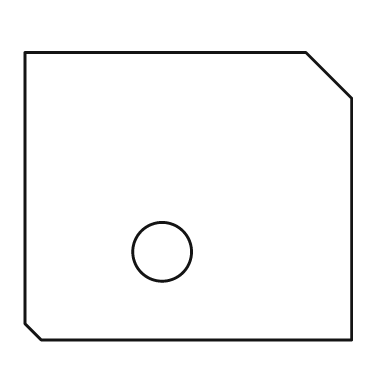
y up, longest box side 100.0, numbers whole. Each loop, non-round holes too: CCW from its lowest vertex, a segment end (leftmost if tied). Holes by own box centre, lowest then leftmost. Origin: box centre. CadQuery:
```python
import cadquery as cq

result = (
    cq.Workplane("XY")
    .moveTo(-45.0, -44.0)
    .lineTo(50.0, -44.0)
    .lineTo(50.0, 30.0)
    .lineTo(36.0, 44.0)
    .lineTo(-50.0, 44.0)
    .lineTo(-50.0, -39.0)
    .close()
    .moveTo(-8.0, -17.0)
    .circle(9.0)
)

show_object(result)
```